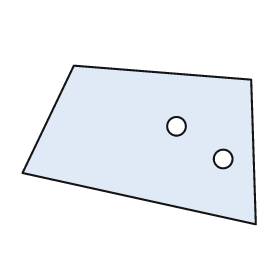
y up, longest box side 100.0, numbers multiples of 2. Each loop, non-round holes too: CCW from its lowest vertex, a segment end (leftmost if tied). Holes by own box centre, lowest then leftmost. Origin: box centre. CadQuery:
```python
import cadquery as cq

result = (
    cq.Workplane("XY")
    .moveTo(50.0, -34.0)
    .lineTo(48.0, 28.0)
    .lineTo(-28.0, 34.0)
    .lineTo(-50.0, -12.0)
    .close()
    .moveTo(36.0, -6.0)
    .circle(4.0)
    .moveTo(16.0, 8.0)
    .circle(4.0)
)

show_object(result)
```